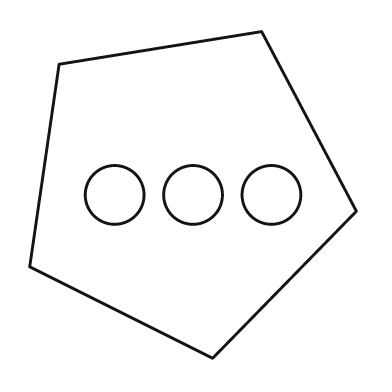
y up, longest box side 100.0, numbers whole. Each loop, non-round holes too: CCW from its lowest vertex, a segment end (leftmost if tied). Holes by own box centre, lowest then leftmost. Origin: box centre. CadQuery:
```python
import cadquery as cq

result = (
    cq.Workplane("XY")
    .moveTo(6.0, -50.0)
    .lineTo(50.0, -5.0)
    .lineTo(21.0, 50.0)
    .lineTo(-41.0, 40.0)
    .lineTo(-50.0, -22.0)
    .close()
    .moveTo(-24.0, 0.0)
    .circle(9.0)
    .moveTo(0.0, 0.0)
    .circle(9.0)
    .moveTo(24.0, 0.0)
    .circle(9.0)
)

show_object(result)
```